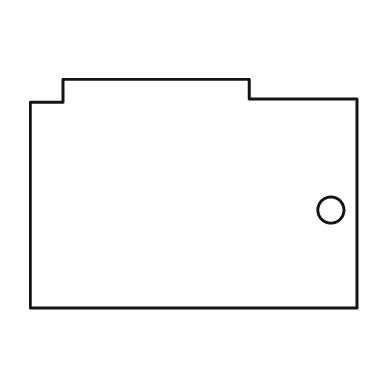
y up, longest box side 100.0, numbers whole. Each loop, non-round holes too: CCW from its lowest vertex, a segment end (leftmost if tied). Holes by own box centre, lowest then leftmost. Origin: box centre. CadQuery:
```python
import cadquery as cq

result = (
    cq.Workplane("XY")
    .moveTo(-50.0, -35.0)
    .lineTo(50.0, -35.0)
    .lineTo(50.0, 29.0)
    .lineTo(17.0, 29.0)
    .lineTo(17.0, 35.0)
    .lineTo(-40.0, 35.0)
    .lineTo(-40.0, 28.0)
    .lineTo(-50.0, 28.0)
    .close()
    .moveTo(42.0, -5.0)
    .circle(4.0)
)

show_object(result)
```